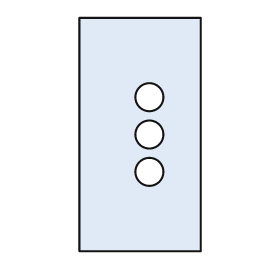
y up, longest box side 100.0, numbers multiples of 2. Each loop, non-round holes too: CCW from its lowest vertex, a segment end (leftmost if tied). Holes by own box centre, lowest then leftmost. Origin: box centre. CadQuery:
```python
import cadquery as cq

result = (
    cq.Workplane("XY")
    .moveTo(-26.0, -50.0)
    .lineTo(26.0, -50.0)
    .lineTo(26.0, 50.0)
    .lineTo(-26.0, 50.0)
    .close()
    .moveTo(4.0, -16.0)
    .circle(6.0)
    .moveTo(4.0, 0.0)
    .circle(6.0)
    .moveTo(4.0, 16.0)
    .circle(6.0)
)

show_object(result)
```